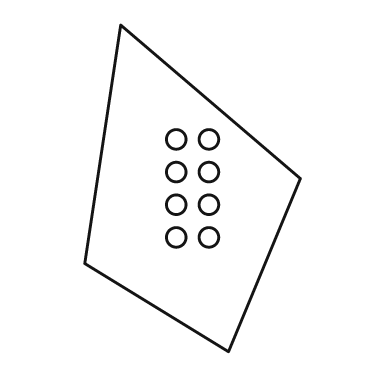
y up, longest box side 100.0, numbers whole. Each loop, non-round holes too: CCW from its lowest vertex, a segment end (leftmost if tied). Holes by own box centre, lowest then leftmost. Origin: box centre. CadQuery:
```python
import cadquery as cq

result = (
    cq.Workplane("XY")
    .moveTo(11.0, -50.0)
    .lineTo(33.0, 3.0)
    .lineTo(-22.0, 50.0)
    .lineTo(-33.0, -23.0)
    .close()
    .moveTo(-5.0, -15.0)
    .circle(3.0)
    .moveTo(5.0, -15.0)
    .circle(3.0)
    .moveTo(-5.0, -5.0)
    .circle(3.0)
    .moveTo(5.0, -5.0)
    .circle(3.0)
    .moveTo(-5.0, 5.0)
    .circle(3.0)
    .moveTo(5.0, 5.0)
    .circle(3.0)
    .moveTo(-5.0, 15.0)
    .circle(3.0)
    .moveTo(5.0, 15.0)
    .circle(3.0)
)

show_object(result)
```